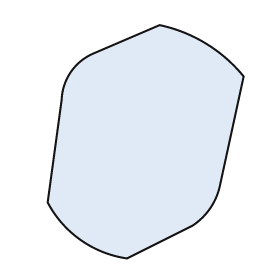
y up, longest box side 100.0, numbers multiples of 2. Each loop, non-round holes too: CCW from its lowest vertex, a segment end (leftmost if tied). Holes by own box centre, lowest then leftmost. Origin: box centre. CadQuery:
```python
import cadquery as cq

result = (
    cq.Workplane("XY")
    .moveTo(-8.0, -50.0)
    .lineTo(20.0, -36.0)
    .threePointArc((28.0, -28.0), (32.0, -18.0))
    .lineTo(42.0, 28.0)
    .threePointArc((26.0, 42.0), (6.0, 50.0))
    .lineTo(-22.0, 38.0)
    .threePointArc((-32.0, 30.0), (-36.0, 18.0))
    .lineTo(-42.0, -26.0)
    .threePointArc((-28.0, -42.0), (-8.0, -50.0))
    .close()
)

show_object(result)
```